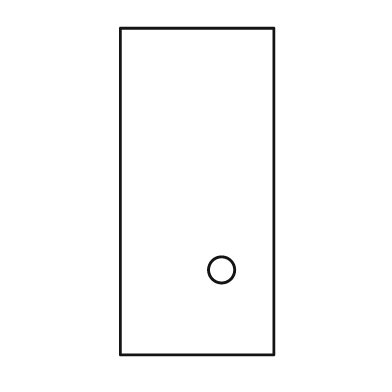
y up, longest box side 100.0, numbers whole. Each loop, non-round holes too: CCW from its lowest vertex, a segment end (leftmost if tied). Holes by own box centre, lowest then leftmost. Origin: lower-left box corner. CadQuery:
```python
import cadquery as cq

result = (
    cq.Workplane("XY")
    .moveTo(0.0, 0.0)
    .lineTo(47.0, 0.0)
    .lineTo(47.0, 100.0)
    .lineTo(0.0, 100.0)
    .close()
    .moveTo(31.0, 26.0)
    .circle(4.0)
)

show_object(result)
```